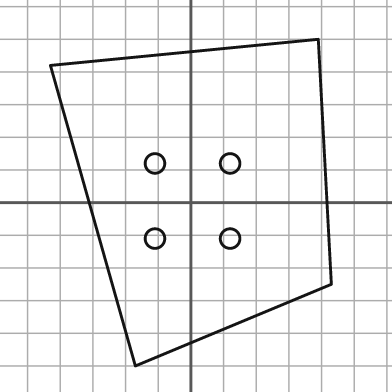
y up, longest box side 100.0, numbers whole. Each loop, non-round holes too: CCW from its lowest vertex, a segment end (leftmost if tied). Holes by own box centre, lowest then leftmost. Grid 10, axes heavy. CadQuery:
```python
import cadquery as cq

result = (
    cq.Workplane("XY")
    .moveTo(-17.0, -50.0)
    .lineTo(43.0, -25.0)
    .lineTo(39.0, 50.0)
    .lineTo(-43.0, 42.0)
    .close()
    .moveTo(-11.0, -11.0)
    .circle(3.0)
    .moveTo(12.0, -11.0)
    .circle(3.0)
    .moveTo(-11.0, 12.0)
    .circle(3.0)
    .moveTo(12.0, 12.0)
    .circle(3.0)
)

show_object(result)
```